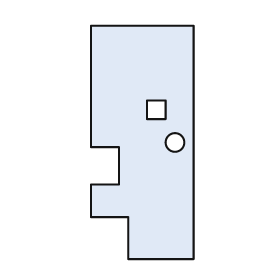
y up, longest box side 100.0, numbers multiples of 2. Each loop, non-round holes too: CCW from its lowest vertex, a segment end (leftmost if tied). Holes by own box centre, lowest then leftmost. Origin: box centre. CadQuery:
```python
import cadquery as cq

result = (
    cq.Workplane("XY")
    .moveTo(-6.0, -50.0)
    .lineTo(22.0, -50.0)
    .lineTo(22.0, 50.0)
    .lineTo(-22.0, 50.0)
    .lineTo(-22.0, -2.0)
    .lineTo(-10.0, -2.0)
    .lineTo(-10.0, -18.0)
    .lineTo(-22.0, -18.0)
    .lineTo(-22.0, -32.0)
    .lineTo(-6.0, -32.0)
    .close()
    .moveTo(14.0, 0.0)
    .circle(4.0)
    .moveTo(2.0, 10.0)
    .lineTo(10.0, 10.0)
    .lineTo(10.0, 18.0)
    .lineTo(2.0, 18.0)
    .close()
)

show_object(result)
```